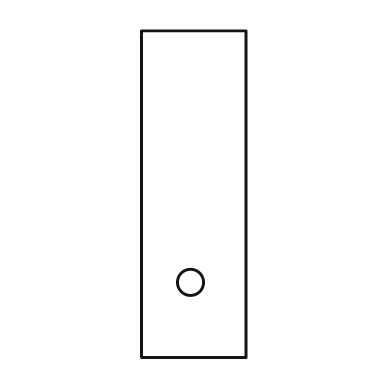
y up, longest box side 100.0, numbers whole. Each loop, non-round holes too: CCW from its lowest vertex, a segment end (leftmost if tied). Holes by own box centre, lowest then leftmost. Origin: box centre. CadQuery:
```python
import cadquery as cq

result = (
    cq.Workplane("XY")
    .moveTo(-16.0, -50.0)
    .lineTo(16.0, -50.0)
    .lineTo(16.0, 50.0)
    .lineTo(-16.0, 50.0)
    .close()
    .moveTo(-1.0, -27.0)
    .circle(4.0)
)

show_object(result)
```